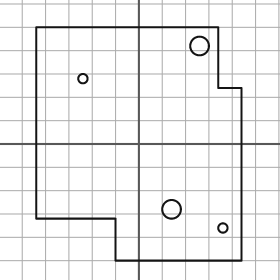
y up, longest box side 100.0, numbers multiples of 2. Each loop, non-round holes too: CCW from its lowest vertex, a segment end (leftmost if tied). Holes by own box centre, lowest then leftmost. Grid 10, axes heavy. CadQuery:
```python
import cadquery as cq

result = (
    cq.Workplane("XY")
    .moveTo(-10.0, -50.0)
    .lineTo(44.0, -50.0)
    .lineTo(44.0, 24.0)
    .lineTo(34.0, 24.0)
    .lineTo(34.0, 50.0)
    .lineTo(-44.0, 50.0)
    .lineTo(-44.0, -32.0)
    .lineTo(-10.0, -32.0)
    .close()
    .moveTo(36.0, -36.0)
    .circle(2.0)
    .moveTo(14.0, -28.0)
    .circle(4.0)
    .moveTo(-24.0, 28.0)
    .circle(2.0)
    .moveTo(26.0, 42.0)
    .circle(4.0)
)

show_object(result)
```